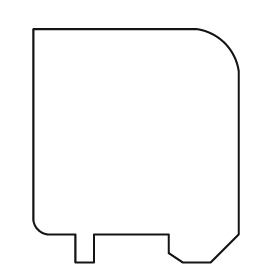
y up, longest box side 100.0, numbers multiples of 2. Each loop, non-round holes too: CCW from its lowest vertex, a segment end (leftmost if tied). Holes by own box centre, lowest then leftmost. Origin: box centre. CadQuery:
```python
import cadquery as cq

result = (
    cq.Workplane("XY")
    .moveTo(-26.0, -50.0)
    .lineTo(-18.0, -50.0)
    .lineTo(-18.0, -38.0)
    .lineTo(14.0, -38.0)
    .lineTo(14.0, -46.0)
    .lineTo(20.0, -50.0)
    .lineTo(32.0, -50.0)
    .lineTo(44.0, -38.0)
    .lineTo(44.0, 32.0)
    .threePointArc((38.0, 44.0), (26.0, 50.0))
    .lineTo(-44.0, 50.0)
    .lineTo(-44.0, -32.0)
    .threePointArc((-42.0, -36.0), (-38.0, -38.0))
    .lineTo(-26.0, -38.0)
    .close()
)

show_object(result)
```